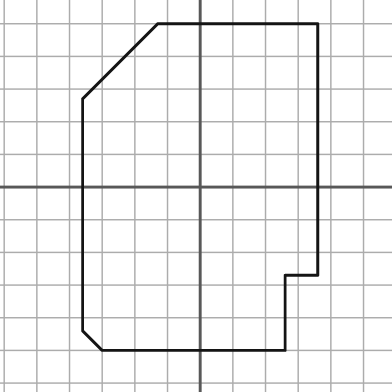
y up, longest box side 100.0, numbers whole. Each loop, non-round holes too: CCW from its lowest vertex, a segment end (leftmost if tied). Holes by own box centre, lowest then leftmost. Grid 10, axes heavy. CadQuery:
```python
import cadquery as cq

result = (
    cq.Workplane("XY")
    .moveTo(-30.0, -50.0)
    .lineTo(26.0, -50.0)
    .lineTo(26.0, -27.0)
    .lineTo(36.0, -27.0)
    .lineTo(36.0, 50.0)
    .lineTo(-13.0, 50.0)
    .lineTo(-36.0, 27.0)
    .lineTo(-36.0, -44.0)
    .close()
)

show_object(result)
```